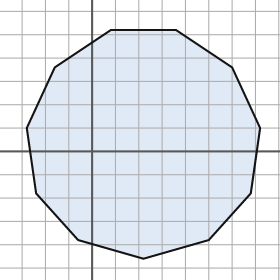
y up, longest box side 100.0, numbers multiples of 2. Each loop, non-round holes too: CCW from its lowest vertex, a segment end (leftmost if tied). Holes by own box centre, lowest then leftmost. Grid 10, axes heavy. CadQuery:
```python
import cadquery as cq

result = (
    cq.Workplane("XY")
    .moveTo(22.0, -46.0)
    .lineTo(50.0, -38.0)
    .lineTo(68.0, -18.0)
    .lineTo(72.0, 10.0)
    .lineTo(60.0, 36.0)
    .lineTo(36.0, 52.0)
    .lineTo(8.0, 52.0)
    .lineTo(-16.0, 36.0)
    .lineTo(-28.0, 10.0)
    .lineTo(-24.0, -18.0)
    .lineTo(-6.0, -38.0)
    .close()
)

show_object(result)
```